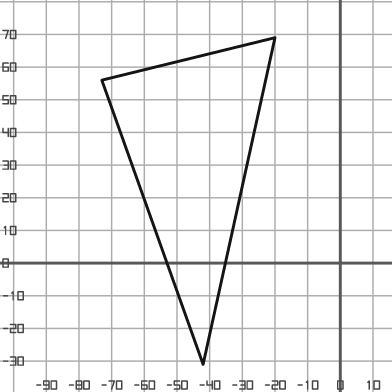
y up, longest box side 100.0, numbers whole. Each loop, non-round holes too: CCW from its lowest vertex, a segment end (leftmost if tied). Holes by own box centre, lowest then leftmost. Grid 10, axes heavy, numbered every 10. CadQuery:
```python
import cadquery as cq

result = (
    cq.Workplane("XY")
    .moveTo(-42.0, -31.0)
    .lineTo(-20.0, 69.0)
    .lineTo(-73.0, 56.0)
    .close()
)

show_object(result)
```